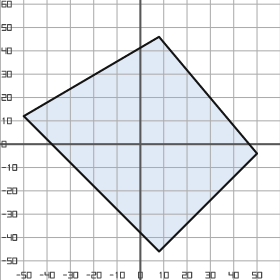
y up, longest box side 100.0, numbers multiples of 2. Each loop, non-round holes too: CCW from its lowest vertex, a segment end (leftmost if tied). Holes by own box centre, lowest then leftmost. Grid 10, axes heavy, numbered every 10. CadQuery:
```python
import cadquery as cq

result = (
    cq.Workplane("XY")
    .moveTo(8.0, -46.0)
    .lineTo(50.0, -4.0)
    .lineTo(8.0, 46.0)
    .lineTo(-50.0, 12.0)
    .close()
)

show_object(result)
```